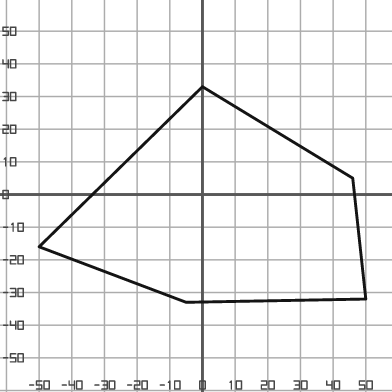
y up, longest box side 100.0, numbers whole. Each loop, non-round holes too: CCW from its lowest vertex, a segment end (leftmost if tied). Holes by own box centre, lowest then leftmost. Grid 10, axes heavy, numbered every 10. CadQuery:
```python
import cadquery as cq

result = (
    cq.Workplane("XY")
    .moveTo(-5.0, -33.0)
    .lineTo(50.0, -32.0)
    .lineTo(46.0, 5.0)
    .lineTo(0.0, 33.0)
    .lineTo(-50.0, -16.0)
    .close()
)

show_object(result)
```